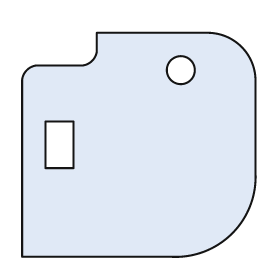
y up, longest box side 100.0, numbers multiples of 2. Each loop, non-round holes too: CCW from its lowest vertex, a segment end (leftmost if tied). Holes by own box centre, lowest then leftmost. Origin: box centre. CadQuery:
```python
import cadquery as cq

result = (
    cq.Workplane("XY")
    .moveTo(-50.0, -48.0)
    .lineTo(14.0, -48.0)
    .threePointArc((40.0, -38.0), (50.0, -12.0))
    .lineTo(50.0, 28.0)
    .threePointArc((44.0, 42.0), (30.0, 48.0))
    .lineTo(-18.0, 48.0)
    .lineTo(-18.0, 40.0)
    .threePointArc((-20.0, 36.0), (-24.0, 34.0))
    .lineTo(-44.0, 34.0)
    .threePointArc((-48.0, 32.0), (-50.0, 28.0))
    .close()
    .moveTo(-40.0, -10.0)
    .lineTo(-28.0, -10.0)
    .lineTo(-28.0, 10.0)
    .lineTo(-40.0, 10.0)
    .close()
    .moveTo(18.0, 32.0)
    .circle(6.0)
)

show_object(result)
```